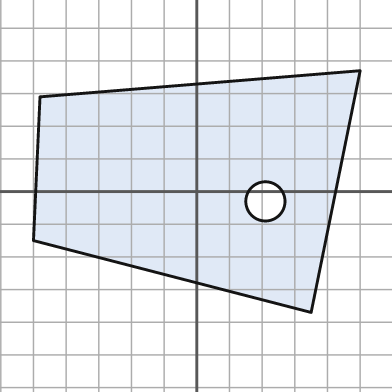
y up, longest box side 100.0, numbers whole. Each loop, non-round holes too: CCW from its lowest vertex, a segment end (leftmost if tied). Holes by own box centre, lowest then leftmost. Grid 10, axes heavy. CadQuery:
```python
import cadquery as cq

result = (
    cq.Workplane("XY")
    .moveTo(35.0, -37.0)
    .lineTo(50.0, 37.0)
    .lineTo(-48.0, 29.0)
    .lineTo(-50.0, -15.0)
    .close()
    .moveTo(21.0, -3.0)
    .circle(6.0)
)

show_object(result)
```